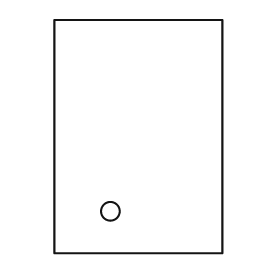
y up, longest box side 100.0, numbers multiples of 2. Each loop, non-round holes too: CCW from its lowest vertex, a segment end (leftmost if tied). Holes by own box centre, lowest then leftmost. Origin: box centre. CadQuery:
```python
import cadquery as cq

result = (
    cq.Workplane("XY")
    .moveTo(-36.0, -50.0)
    .lineTo(36.0, -50.0)
    .lineTo(36.0, 50.0)
    .lineTo(-36.0, 50.0)
    .close()
    .moveTo(-12.0, -32.0)
    .circle(4.0)
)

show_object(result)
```